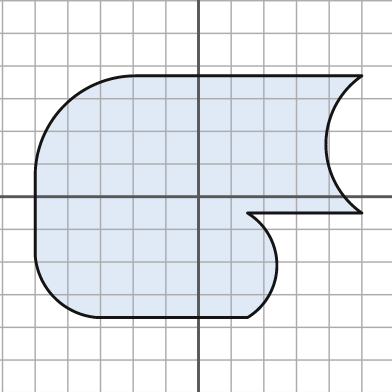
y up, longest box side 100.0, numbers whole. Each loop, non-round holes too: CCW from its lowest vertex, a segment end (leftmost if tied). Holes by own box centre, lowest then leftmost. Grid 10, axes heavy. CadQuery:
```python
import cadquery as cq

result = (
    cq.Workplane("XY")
    .moveTo(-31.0, -37.0)
    .lineTo(15.0, -37.0)
    .threePointArc((24.0, -21.0), (15.0, -5.0))
    .lineTo(50.0, -5.0)
    .threePointArc((39.0, 16.0), (50.0, 37.0))
    .lineTo(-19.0, 37.0)
    .threePointArc((-41.0, 28.0), (-50.0, 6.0))
    .lineTo(-50.0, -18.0)
    .threePointArc((-44.0, -31.0), (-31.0, -37.0))
    .close()
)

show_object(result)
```